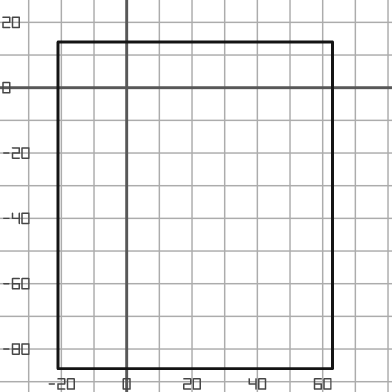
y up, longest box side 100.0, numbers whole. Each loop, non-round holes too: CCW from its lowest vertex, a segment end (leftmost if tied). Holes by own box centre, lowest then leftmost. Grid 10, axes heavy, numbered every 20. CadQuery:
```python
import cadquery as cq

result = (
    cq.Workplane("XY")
    .moveTo(-21.0, -86.0)
    .lineTo(63.0, -86.0)
    .lineTo(63.0, 14.0)
    .lineTo(-21.0, 14.0)
    .close()
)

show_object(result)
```